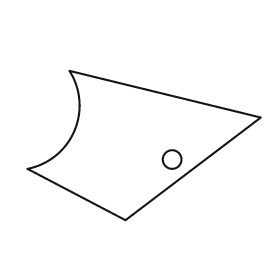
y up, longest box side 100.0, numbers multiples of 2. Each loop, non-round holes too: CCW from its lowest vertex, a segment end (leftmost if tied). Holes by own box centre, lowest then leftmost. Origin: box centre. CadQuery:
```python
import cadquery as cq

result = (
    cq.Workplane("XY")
    .moveTo(-8.0, -32.0)
    .lineTo(50.0, 12.0)
    .lineTo(-32.0, 32.0)
    .threePointArc((-30.0, 6.0), (-50.0, -10.0))
    .close()
    .moveTo(12.0, -6.0)
    .circle(4.0)
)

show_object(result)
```